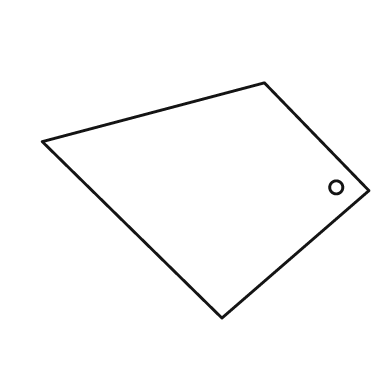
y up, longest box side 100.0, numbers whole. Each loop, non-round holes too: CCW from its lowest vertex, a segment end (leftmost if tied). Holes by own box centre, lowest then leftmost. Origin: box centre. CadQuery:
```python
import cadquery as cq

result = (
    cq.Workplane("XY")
    .moveTo(5.0, -36.0)
    .lineTo(50.0, 3.0)
    .lineTo(18.0, 36.0)
    .lineTo(-50.0, 18.0)
    .close()
    .moveTo(40.0, 4.0)
    .circle(2.0)
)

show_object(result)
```